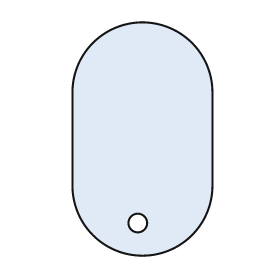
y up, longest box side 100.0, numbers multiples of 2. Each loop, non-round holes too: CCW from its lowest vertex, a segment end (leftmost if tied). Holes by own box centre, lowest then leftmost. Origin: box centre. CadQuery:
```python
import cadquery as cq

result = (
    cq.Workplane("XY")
    .moveTo(-30.0, -20.0)
    .threePointArc((0.0, -50.0), (30.0, -20.0))
    .lineTo(30.0, 20.0)
    .threePointArc((0.0, 50.0), (-30.0, 20.0))
    .close()
    .moveTo(-2.0, -36.0)
    .circle(4.0)
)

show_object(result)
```